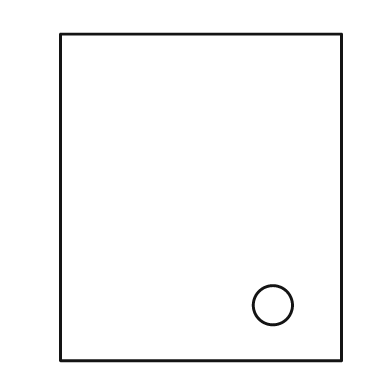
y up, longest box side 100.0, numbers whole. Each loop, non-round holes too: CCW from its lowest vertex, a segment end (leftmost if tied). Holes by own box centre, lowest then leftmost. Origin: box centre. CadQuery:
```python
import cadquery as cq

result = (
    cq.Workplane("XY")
    .moveTo(-43.0, -50.0)
    .lineTo(43.0, -50.0)
    .lineTo(43.0, 50.0)
    .lineTo(-43.0, 50.0)
    .close()
    .moveTo(22.0, -33.0)
    .circle(6.0)
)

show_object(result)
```